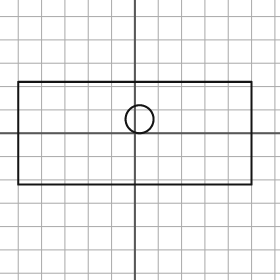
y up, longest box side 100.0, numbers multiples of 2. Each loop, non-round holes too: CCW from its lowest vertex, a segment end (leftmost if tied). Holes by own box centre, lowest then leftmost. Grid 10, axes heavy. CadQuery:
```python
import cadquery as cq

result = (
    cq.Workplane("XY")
    .moveTo(-50.0, -22.0)
    .lineTo(50.0, -22.0)
    .lineTo(50.0, 22.0)
    .lineTo(-50.0, 22.0)
    .close()
    .moveTo(2.0, 6.0)
    .circle(6.0)
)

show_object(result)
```